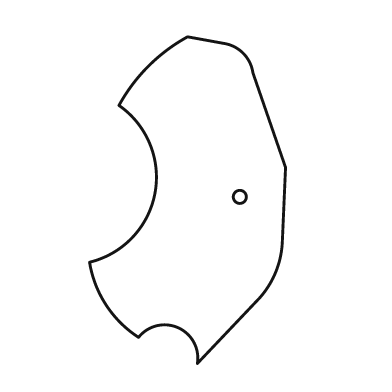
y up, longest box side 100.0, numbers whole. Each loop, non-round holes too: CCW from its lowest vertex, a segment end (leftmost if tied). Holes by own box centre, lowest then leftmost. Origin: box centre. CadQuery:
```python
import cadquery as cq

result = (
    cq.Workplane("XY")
    .moveTo(3.0, -50.0)
    .lineTo(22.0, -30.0)
    .threePointArc((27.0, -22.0), (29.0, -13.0))
    .lineTo(30.0, 10.0)
    .lineTo(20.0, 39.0)
    .threePointArc((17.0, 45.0), (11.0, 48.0))
    .lineTo(0.0, 50.0)
    .threePointArc((-12.0, 41.0), (-21.0, 29.0))
    .threePointArc((-10.0, 2.0), (-30.0, -19.0))
    .threePointArc((-25.0, -32.0), (-15.0, -42.0))
    .threePointArc((-3.0, -39.0), (3.0, -50.0))
    .close()
    .moveTo(16.0, 1.0)
    .circle(2.0)
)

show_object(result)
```